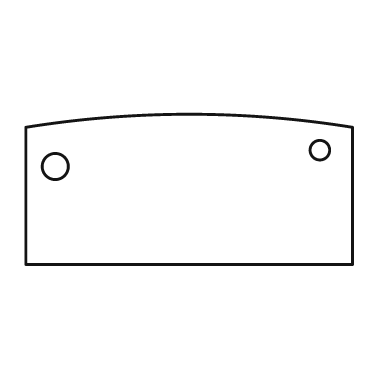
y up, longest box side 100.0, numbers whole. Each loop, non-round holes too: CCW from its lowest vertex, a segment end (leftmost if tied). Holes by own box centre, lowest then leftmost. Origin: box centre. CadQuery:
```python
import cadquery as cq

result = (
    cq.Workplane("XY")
    .moveTo(-50.0, -23.0)
    .lineTo(50.0, -23.0)
    .lineTo(50.0, 19.0)
    .threePointArc((0.0, 23.0), (-50.0, 19.0))
    .close()
    .moveTo(-41.0, 7.0)
    .circle(4.0)
    .moveTo(40.0, 12.0)
    .circle(3.0)
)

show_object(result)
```